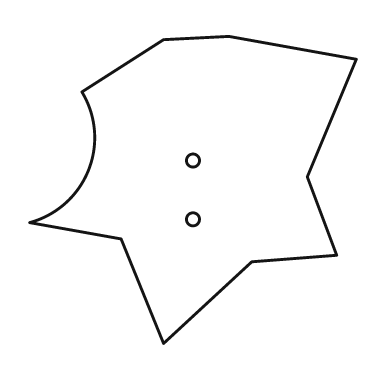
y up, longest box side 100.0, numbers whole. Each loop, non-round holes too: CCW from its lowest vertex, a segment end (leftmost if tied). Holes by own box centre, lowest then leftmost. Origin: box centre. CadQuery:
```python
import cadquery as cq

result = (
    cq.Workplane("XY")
    .moveTo(-9.0, -47.0)
    .lineTo(18.0, -22.0)
    .lineTo(44.0, -20.0)
    .lineTo(35.0, 4.0)
    .lineTo(50.0, 40.0)
    .lineTo(11.0, 47.0)
    .lineTo(-9.0, 46.0)
    .lineTo(-34.0, 30.0)
    .threePointArc((-32.0, 6.0), (-50.0, -10.0))
    .lineTo(-22.0, -15.0)
    .close()
    .moveTo(0.0, -9.0)
    .circle(2.0)
    .moveTo(0.0, 9.0)
    .circle(2.0)
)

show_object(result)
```